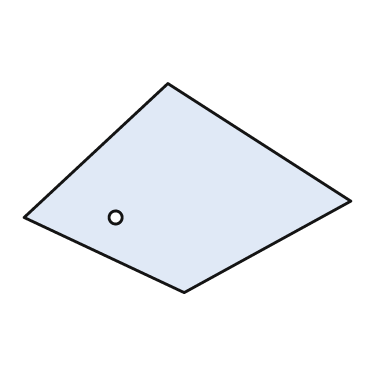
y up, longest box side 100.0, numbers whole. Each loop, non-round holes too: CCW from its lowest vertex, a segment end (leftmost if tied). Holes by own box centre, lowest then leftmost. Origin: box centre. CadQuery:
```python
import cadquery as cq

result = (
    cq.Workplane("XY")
    .moveTo(-1.0, -32.0)
    .lineTo(50.0, -4.0)
    .lineTo(-6.0, 32.0)
    .lineTo(-50.0, -9.0)
    .close()
    .moveTo(-22.0, -9.0)
    .circle(2.0)
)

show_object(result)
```